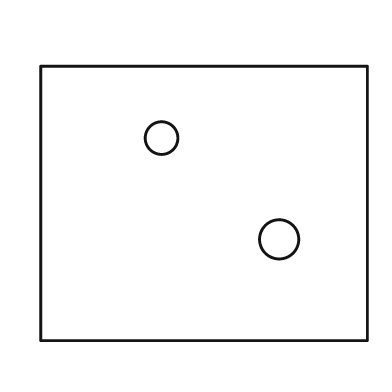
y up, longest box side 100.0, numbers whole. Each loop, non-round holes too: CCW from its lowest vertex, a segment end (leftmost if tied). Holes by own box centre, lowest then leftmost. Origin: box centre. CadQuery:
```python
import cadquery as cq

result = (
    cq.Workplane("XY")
    .moveTo(-50.0, -42.0)
    .lineTo(50.0, -42.0)
    .lineTo(50.0, 42.0)
    .lineTo(-50.0, 42.0)
    .close()
    .moveTo(23.0, -11.0)
    .circle(6.0)
    .moveTo(-13.0, 20.0)
    .circle(5.0)
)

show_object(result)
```